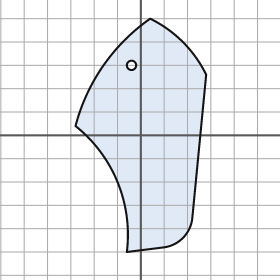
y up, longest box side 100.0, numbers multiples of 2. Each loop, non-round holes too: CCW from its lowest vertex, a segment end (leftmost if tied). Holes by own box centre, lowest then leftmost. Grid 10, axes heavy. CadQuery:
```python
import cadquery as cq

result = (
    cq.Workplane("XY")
    .moveTo(-6.0, -50.0)
    .lineTo(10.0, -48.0)
    .threePointArc((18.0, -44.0), (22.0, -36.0))
    .lineTo(28.0, 26.0)
    .threePointArc((18.0, 40.0), (4.0, 50.0))
    .threePointArc((-16.0, 30.0), (-28.0, 4.0))
    .threePointArc((-10.0, -20.0), (-6.0, -50.0))
    .close()
    .moveTo(-4.0, 30.0)
    .circle(2.0)
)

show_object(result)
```